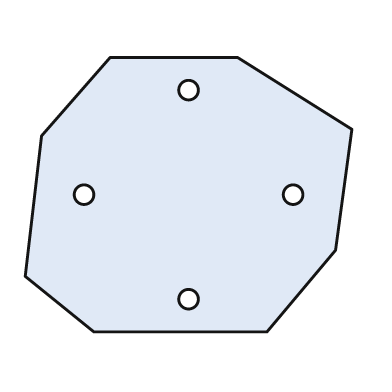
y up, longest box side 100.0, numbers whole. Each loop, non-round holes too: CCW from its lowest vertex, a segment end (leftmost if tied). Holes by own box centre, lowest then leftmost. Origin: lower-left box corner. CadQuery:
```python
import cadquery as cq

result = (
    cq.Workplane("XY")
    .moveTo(21.0, 0.0)
    .lineTo(74.0, 0.0)
    .lineTo(95.0, 25.0)
    .lineTo(100.0, 62.0)
    .lineTo(65.0, 84.0)
    .lineTo(26.0, 84.0)
    .lineTo(5.0, 60.0)
    .lineTo(0.0, 17.0)
    .close()
    .moveTo(50.0, 10.0)
    .circle(3.0)
    .moveTo(18.0, 42.0)
    .circle(3.0)
    .moveTo(82.0, 42.0)
    .circle(3.0)
    .moveTo(50.0, 74.0)
    .circle(3.0)
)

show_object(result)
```